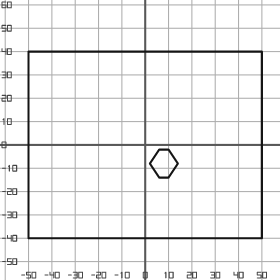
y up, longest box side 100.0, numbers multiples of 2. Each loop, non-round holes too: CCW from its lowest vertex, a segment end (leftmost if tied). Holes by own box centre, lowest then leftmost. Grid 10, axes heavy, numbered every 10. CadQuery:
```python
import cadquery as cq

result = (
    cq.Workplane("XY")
    .moveTo(-50.0, -40.0)
    .lineTo(50.0, -40.0)
    .lineTo(50.0, 40.0)
    .lineTo(-50.0, 40.0)
    .close()
    .moveTo(6.0, -14.0)
    .lineTo(10.0, -14.0)
    .lineTo(14.0, -8.0)
    .lineTo(10.0, -2.0)
    .lineTo(6.0, -2.0)
    .lineTo(2.0, -8.0)
    .close()
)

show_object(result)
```